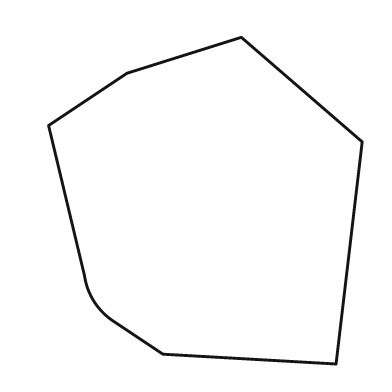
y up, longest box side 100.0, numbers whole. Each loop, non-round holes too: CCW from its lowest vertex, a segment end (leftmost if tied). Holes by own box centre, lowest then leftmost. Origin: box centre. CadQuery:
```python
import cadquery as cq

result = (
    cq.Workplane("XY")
    .moveTo(40.0, -50.0)
    .lineTo(48.0, 18.0)
    .lineTo(11.0, 50.0)
    .lineTo(-24.0, 39.0)
    .lineTo(-48.0, 23.0)
    .lineTo(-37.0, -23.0)
    .threePointArc((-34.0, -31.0), (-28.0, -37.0))
    .lineTo(-13.0, -47.0)
    .close()
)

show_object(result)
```